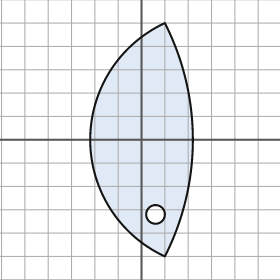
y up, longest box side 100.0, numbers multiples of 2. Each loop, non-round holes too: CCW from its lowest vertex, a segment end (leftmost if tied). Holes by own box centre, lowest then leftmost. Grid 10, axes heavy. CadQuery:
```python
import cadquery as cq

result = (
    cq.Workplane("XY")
    .moveTo(10.0, -50.0)
    .threePointArc((22.0, 0.0), (10.0, 50.0))
    .threePointArc((-22.0, 0.0), (10.0, -50.0))
    .close()
    .moveTo(6.0, -32.0)
    .circle(4.0)
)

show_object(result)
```